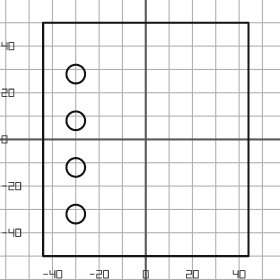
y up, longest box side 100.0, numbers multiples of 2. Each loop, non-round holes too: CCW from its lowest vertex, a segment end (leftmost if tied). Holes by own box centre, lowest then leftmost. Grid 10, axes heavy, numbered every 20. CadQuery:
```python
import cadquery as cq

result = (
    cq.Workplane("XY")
    .moveTo(-44.0, -50.0)
    .lineTo(44.0, -50.0)
    .lineTo(44.0, 50.0)
    .lineTo(-44.0, 50.0)
    .close()
    .moveTo(-30.0, -32.0)
    .circle(4.0)
    .moveTo(-30.0, -12.0)
    .circle(4.0)
    .moveTo(-30.0, 8.0)
    .circle(4.0)
    .moveTo(-30.0, 28.0)
    .circle(4.0)
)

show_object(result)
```